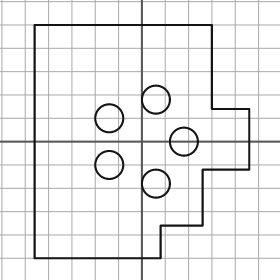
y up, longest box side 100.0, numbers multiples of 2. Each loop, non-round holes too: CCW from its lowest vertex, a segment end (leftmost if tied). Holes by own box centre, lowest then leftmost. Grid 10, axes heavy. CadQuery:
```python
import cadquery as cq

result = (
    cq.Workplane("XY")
    .moveTo(-46.0, -50.0)
    .lineTo(8.0, -50.0)
    .lineTo(8.0, -36.0)
    .lineTo(26.0, -36.0)
    .lineTo(26.0, -12.0)
    .lineTo(46.0, -12.0)
    .lineTo(46.0, 14.0)
    .lineTo(30.0, 14.0)
    .lineTo(30.0, 50.0)
    .lineTo(-46.0, 50.0)
    .close()
    .moveTo(6.0, -18.0)
    .circle(6.0)
    .moveTo(-14.0, -10.0)
    .circle(6.0)
    .moveTo(18.0, 0.0)
    .circle(6.0)
    .moveTo(-14.0, 10.0)
    .circle(6.0)
    .moveTo(6.0, 18.0)
    .circle(6.0)
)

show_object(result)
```